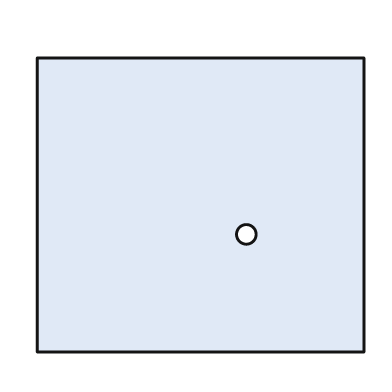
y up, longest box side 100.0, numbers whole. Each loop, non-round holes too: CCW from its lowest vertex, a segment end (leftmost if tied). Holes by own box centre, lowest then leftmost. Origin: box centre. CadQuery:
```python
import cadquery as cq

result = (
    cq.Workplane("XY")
    .moveTo(-50.0, -45.0)
    .lineTo(50.0, -45.0)
    .lineTo(50.0, 45.0)
    .lineTo(-50.0, 45.0)
    .close()
    .moveTo(14.0, -9.0)
    .circle(3.0)
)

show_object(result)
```